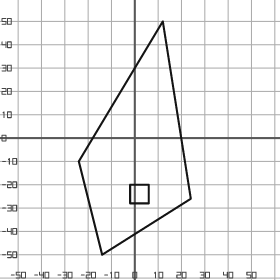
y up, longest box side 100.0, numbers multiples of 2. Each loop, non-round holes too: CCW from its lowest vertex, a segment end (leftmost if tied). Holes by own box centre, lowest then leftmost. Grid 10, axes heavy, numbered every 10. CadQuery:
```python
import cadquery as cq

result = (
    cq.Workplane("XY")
    .moveTo(-14.0, -50.0)
    .lineTo(24.0, -26.0)
    .lineTo(12.0, 50.0)
    .lineTo(-24.0, -10.0)
    .close()
    .moveTo(-2.0, -28.0)
    .lineTo(6.0, -28.0)
    .lineTo(6.0, -20.0)
    .lineTo(-2.0, -20.0)
    .close()
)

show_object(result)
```